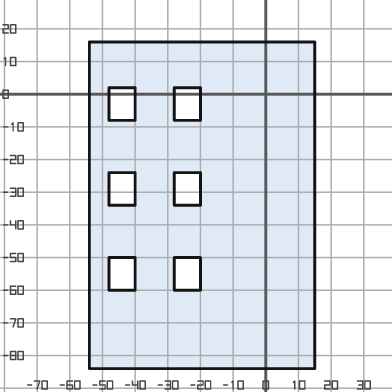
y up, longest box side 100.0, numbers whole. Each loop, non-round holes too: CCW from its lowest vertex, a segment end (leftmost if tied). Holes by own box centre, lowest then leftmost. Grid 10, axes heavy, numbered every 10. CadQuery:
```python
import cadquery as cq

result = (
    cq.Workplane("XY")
    .moveTo(-54.0, -84.0)
    .lineTo(15.0, -84.0)
    .lineTo(15.0, 16.0)
    .lineTo(-54.0, 16.0)
    .close()
    .moveTo(-48.0, -60.0)
    .lineTo(-40.0, -60.0)
    .lineTo(-40.0, -50.0)
    .lineTo(-48.0, -50.0)
    .close()
    .moveTo(-28.0, -60.0)
    .lineTo(-20.0, -60.0)
    .lineTo(-20.0, -50.0)
    .lineTo(-28.0, -50.0)
    .close()
    .moveTo(-48.0, -34.0)
    .lineTo(-40.0, -34.0)
    .lineTo(-40.0, -24.0)
    .lineTo(-48.0, -24.0)
    .close()
    .moveTo(-28.0, -34.0)
    .lineTo(-20.0, -34.0)
    .lineTo(-20.0, -24.0)
    .lineTo(-28.0, -24.0)
    .close()
    .moveTo(-48.0, -8.0)
    .lineTo(-40.0, -8.0)
    .lineTo(-40.0, 2.0)
    .lineTo(-48.0, 2.0)
    .close()
    .moveTo(-28.0, -8.0)
    .lineTo(-20.0, -8.0)
    .lineTo(-20.0, 2.0)
    .lineTo(-28.0, 2.0)
    .close()
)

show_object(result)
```